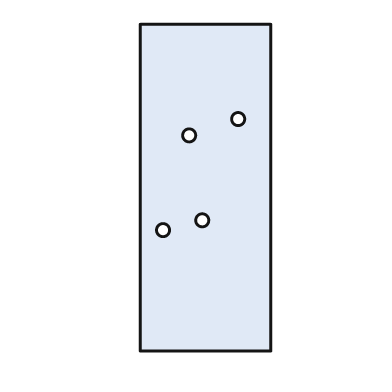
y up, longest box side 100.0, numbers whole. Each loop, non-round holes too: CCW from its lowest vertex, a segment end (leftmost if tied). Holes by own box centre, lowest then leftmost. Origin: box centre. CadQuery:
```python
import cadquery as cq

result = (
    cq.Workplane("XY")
    .moveTo(-20.0, -50.0)
    .lineTo(20.0, -50.0)
    .lineTo(20.0, 50.0)
    .lineTo(-20.0, 50.0)
    .close()
    .moveTo(-13.0, -13.0)
    .circle(2.0)
    .moveTo(-1.0, -10.0)
    .circle(2.0)
    .moveTo(-5.0, 16.0)
    .circle(2.0)
    .moveTo(10.0, 21.0)
    .circle(2.0)
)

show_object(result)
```